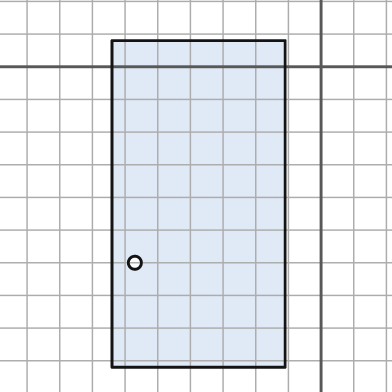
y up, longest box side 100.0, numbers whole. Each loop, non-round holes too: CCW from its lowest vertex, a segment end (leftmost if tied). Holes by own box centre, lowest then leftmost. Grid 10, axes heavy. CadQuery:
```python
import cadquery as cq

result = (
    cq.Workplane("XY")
    .moveTo(-64.0, -92.0)
    .lineTo(-11.0, -92.0)
    .lineTo(-11.0, 8.0)
    .lineTo(-64.0, 8.0)
    .close()
    .moveTo(-57.0, -60.0)
    .circle(2.0)
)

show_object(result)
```